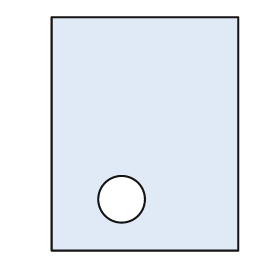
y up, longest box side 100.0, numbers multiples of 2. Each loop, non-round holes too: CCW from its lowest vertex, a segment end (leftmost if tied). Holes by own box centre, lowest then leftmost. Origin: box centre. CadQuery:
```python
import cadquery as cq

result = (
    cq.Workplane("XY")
    .moveTo(-40.0, -50.0)
    .lineTo(40.0, -50.0)
    .lineTo(40.0, 50.0)
    .lineTo(-40.0, 50.0)
    .close()
    .moveTo(-10.0, -28.0)
    .circle(10.0)
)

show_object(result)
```